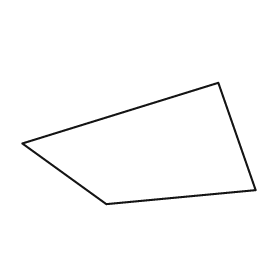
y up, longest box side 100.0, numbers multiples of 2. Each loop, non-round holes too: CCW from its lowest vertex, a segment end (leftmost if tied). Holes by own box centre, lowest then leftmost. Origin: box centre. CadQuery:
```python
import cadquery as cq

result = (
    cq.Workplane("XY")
    .moveTo(-14.0, -26.0)
    .lineTo(50.0, -20.0)
    .lineTo(34.0, 26.0)
    .lineTo(-50.0, 0.0)
    .close()
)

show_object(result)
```